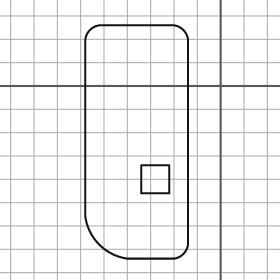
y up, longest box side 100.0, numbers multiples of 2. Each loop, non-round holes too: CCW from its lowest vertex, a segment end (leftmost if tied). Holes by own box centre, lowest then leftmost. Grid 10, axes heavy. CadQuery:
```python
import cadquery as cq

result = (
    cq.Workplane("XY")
    .moveTo(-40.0, -74.0)
    .lineTo(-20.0, -74.0)
    .threePointArc((-16.0, -72.0), (-14.0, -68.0))
    .lineTo(-14.0, 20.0)
    .threePointArc((-16.0, 24.0), (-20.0, 26.0))
    .lineTo(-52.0, 26.0)
    .threePointArc((-56.0, 24.0), (-58.0, 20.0))
    .lineTo(-58.0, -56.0)
    .threePointArc((-52.0, -68.0), (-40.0, -74.0))
    .close()
    .moveTo(-34.0, -46.0)
    .lineTo(-22.0, -46.0)
    .lineTo(-22.0, -34.0)
    .lineTo(-34.0, -34.0)
    .close()
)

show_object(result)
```